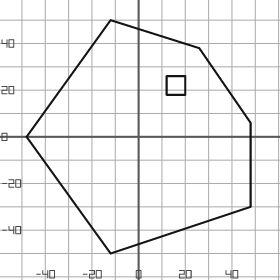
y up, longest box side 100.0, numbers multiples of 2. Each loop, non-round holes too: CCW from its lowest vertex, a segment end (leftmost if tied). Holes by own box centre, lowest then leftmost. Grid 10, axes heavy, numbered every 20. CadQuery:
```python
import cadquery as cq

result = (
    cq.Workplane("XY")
    .moveTo(-12.0, -50.0)
    .lineTo(48.0, -30.0)
    .lineTo(48.0, 6.0)
    .lineTo(26.0, 38.0)
    .lineTo(-12.0, 50.0)
    .lineTo(-48.0, 0.0)
    .close()
    .moveTo(12.0, 18.0)
    .lineTo(20.0, 18.0)
    .lineTo(20.0, 26.0)
    .lineTo(12.0, 26.0)
    .close()
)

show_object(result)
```